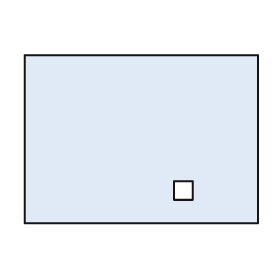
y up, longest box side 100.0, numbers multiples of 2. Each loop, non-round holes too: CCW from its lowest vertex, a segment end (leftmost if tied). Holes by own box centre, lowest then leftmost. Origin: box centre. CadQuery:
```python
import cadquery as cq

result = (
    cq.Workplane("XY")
    .moveTo(-50.0, -36.0)
    .lineTo(50.0, -36.0)
    .lineTo(50.0, 36.0)
    .lineTo(-50.0, 36.0)
    .close()
    .moveTo(14.0, -26.0)
    .lineTo(22.0, -26.0)
    .lineTo(22.0, -18.0)
    .lineTo(14.0, -18.0)
    .close()
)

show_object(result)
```